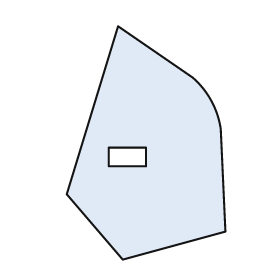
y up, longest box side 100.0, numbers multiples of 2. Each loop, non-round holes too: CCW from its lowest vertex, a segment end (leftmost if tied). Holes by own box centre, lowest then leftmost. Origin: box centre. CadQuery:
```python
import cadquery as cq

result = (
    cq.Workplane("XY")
    .moveTo(-10.0, -50.0)
    .lineTo(34.0, -38.0)
    .lineTo(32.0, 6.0)
    .threePointArc((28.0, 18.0), (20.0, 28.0))
    .lineTo(-12.0, 50.0)
    .lineTo(-34.0, -22.0)
    .close()
    .moveTo(-16.0, -10.0)
    .lineTo(0.0, -10.0)
    .lineTo(0.0, -2.0)
    .lineTo(-16.0, -2.0)
    .close()
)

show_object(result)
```